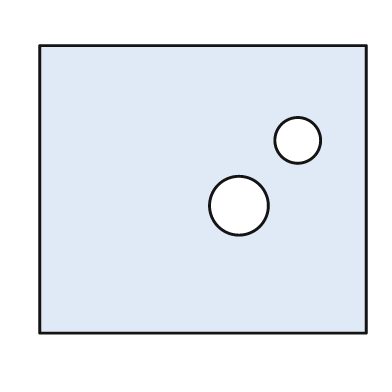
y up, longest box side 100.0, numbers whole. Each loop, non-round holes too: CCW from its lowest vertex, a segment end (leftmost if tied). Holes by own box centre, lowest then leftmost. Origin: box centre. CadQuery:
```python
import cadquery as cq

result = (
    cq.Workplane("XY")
    .moveTo(-50.0, -44.0)
    .lineTo(50.0, -44.0)
    .lineTo(50.0, 44.0)
    .lineTo(-50.0, 44.0)
    .close()
    .moveTo(11.0, -5.0)
    .circle(9.0)
    .moveTo(29.0, 15.0)
    .circle(7.0)
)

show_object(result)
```